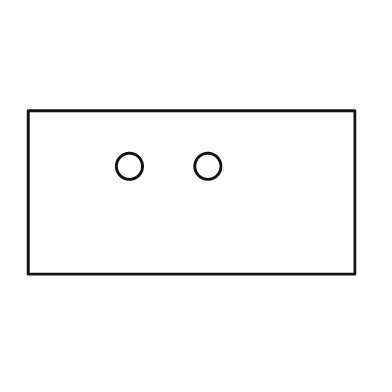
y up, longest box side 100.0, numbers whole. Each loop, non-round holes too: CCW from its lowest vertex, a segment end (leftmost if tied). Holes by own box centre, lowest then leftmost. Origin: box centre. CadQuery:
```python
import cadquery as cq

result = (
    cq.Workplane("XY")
    .moveTo(-50.0, -25.0)
    .lineTo(50.0, -25.0)
    .lineTo(50.0, 25.0)
    .lineTo(-50.0, 25.0)
    .close()
    .moveTo(-19.0, 8.0)
    .circle(4.0)
    .moveTo(5.0, 8.0)
    .circle(4.0)
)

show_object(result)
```